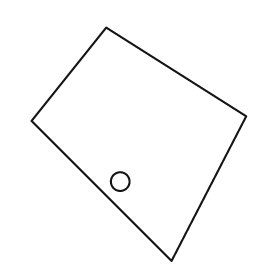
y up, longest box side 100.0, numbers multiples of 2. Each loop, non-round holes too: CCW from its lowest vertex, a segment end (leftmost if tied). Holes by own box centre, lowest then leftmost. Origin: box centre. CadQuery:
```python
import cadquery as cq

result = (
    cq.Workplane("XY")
    .moveTo(14.0, -50.0)
    .lineTo(46.0, 12.0)
    .lineTo(-14.0, 50.0)
    .lineTo(-46.0, 10.0)
    .close()
    .moveTo(-8.0, -16.0)
    .circle(4.0)
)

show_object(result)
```